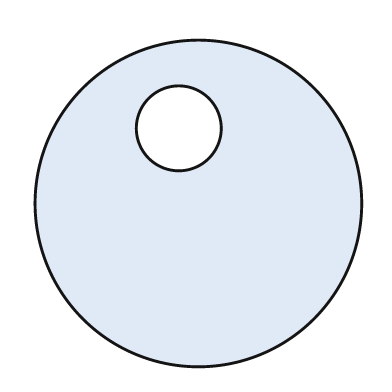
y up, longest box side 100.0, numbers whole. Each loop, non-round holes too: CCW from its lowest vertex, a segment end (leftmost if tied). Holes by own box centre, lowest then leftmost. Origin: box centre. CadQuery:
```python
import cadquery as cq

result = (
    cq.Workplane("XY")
    .moveTo(0.0, 0.0)
    .circle(50.0)
    .moveTo(-6.0, 23.0)
    .circle(13.0)
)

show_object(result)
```